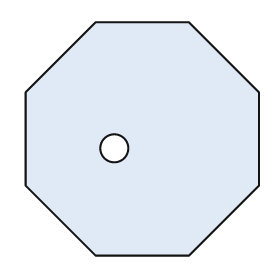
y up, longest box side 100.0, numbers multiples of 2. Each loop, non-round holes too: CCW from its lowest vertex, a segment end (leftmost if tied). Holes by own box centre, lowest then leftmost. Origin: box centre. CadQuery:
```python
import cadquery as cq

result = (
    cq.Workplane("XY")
    .moveTo(-20.0, -50.0)
    .lineTo(20.0, -50.0)
    .lineTo(50.0, -20.0)
    .lineTo(50.0, 20.0)
    .lineTo(20.0, 50.0)
    .lineTo(-20.0, 50.0)
    .lineTo(-50.0, 20.0)
    .lineTo(-50.0, -20.0)
    .close()
    .moveTo(-12.0, -4.0)
    .circle(6.0)
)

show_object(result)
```